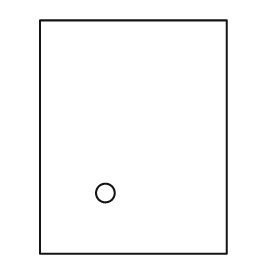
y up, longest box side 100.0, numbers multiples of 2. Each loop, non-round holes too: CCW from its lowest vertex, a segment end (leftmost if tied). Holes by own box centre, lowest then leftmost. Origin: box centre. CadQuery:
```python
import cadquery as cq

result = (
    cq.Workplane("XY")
    .moveTo(-40.0, -50.0)
    .lineTo(40.0, -50.0)
    .lineTo(40.0, 50.0)
    .lineTo(-40.0, 50.0)
    .close()
    .moveTo(-12.0, -24.0)
    .circle(4.0)
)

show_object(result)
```